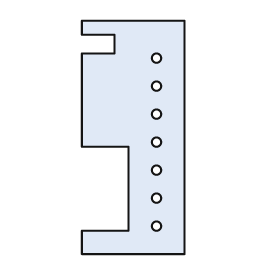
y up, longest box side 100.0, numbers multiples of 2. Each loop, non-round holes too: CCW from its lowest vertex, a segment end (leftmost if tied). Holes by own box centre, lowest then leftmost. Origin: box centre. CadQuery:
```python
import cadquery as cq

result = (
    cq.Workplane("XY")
    .moveTo(-22.0, -50.0)
    .lineTo(22.0, -50.0)
    .lineTo(22.0, 50.0)
    .lineTo(-22.0, 50.0)
    .lineTo(-22.0, 44.0)
    .lineTo(-8.0, 44.0)
    .lineTo(-8.0, 36.0)
    .lineTo(-22.0, 36.0)
    .lineTo(-22.0, -4.0)
    .lineTo(-2.0, -4.0)
    .lineTo(-2.0, -40.0)
    .lineTo(-22.0, -40.0)
    .close()
    .moveTo(10.0, -38.0)
    .circle(2.0)
    .moveTo(10.0, -26.0)
    .circle(2.0)
    .moveTo(10.0, -14.0)
    .circle(2.0)
    .moveTo(10.0, -2.0)
    .circle(2.0)
    .moveTo(10.0, 10.0)
    .circle(2.0)
    .moveTo(10.0, 22.0)
    .circle(2.0)
    .moveTo(10.0, 34.0)
    .circle(2.0)
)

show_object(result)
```